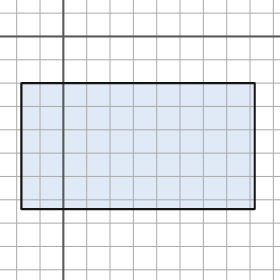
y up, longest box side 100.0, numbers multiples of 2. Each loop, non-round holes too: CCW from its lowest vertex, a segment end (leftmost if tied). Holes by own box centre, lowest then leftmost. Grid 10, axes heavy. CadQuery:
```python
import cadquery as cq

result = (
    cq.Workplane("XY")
    .moveTo(-18.0, -74.0)
    .lineTo(82.0, -74.0)
    .lineTo(82.0, -20.0)
    .lineTo(-18.0, -20.0)
    .close()
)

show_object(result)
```